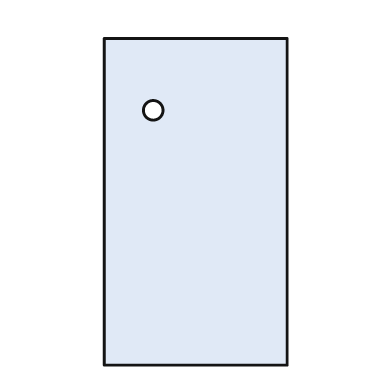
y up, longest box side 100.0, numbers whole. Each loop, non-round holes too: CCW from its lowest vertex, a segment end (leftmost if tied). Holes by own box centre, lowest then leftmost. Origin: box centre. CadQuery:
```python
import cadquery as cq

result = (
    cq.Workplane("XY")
    .moveTo(-28.0, -50.0)
    .lineTo(28.0, -50.0)
    .lineTo(28.0, 50.0)
    .lineTo(-28.0, 50.0)
    .close()
    .moveTo(-13.0, 28.0)
    .circle(3.0)
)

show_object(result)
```